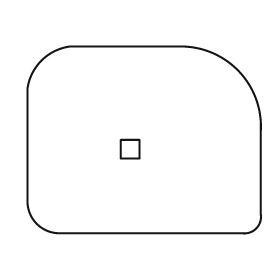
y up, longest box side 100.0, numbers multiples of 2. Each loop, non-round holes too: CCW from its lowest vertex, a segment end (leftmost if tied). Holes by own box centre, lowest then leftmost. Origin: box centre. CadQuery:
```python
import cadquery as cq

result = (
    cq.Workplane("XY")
    .moveTo(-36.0, -40.0)
    .lineTo(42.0, -40.0)
    .threePointArc((48.0, -38.0), (50.0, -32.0))
    .lineTo(50.0, 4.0)
    .threePointArc((40.0, 30.0), (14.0, 40.0))
    .lineTo(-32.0, 40.0)
    .threePointArc((-44.0, 34.0), (-50.0, 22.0))
    .lineTo(-50.0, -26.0)
    .threePointArc((-46.0, -36.0), (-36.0, -40.0))
    .close()
    .moveTo(-10.0, -8.0)
    .lineTo(-2.0, -8.0)
    .lineTo(-2.0, 0.0)
    .lineTo(-10.0, 0.0)
    .close()
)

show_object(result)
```